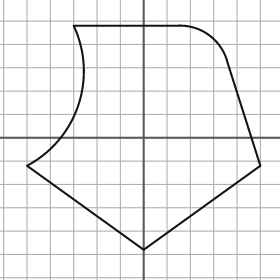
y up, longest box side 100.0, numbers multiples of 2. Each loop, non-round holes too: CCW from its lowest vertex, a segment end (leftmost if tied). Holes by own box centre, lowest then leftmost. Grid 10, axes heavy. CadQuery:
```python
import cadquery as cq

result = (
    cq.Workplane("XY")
    .moveTo(0.0, -48.0)
    .lineTo(50.0, -12.0)
    .lineTo(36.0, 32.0)
    .threePointArc((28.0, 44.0), (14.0, 48.0))
    .lineTo(-30.0, 48.0)
    .threePointArc((-28.0, 14.0), (-50.0, -12.0))
    .close()
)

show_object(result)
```